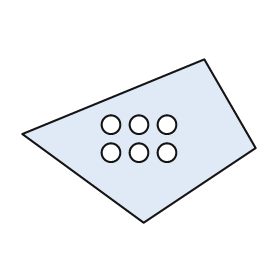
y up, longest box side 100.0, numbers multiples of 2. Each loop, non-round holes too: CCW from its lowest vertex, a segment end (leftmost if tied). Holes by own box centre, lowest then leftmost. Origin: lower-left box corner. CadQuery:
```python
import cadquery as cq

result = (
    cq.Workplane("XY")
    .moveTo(52.0, 0.0)
    .lineTo(100.0, 32.0)
    .lineTo(78.0, 70.0)
    .lineTo(0.0, 38.0)
    .close()
    .moveTo(38.0, 30.0)
    .circle(4.0)
    .moveTo(50.0, 30.0)
    .circle(4.0)
    .moveTo(62.0, 30.0)
    .circle(4.0)
    .moveTo(38.0, 42.0)
    .circle(4.0)
    .moveTo(50.0, 42.0)
    .circle(4.0)
    .moveTo(62.0, 42.0)
    .circle(4.0)
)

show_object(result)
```